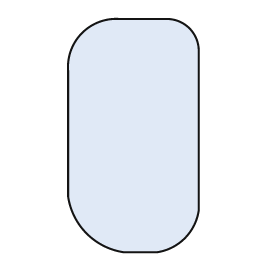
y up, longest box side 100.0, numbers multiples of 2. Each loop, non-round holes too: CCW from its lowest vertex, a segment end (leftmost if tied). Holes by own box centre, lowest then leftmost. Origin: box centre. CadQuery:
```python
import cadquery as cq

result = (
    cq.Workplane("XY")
    .moveTo(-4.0, -50.0)
    .lineTo(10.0, -50.0)
    .threePointArc((22.0, -44.0), (28.0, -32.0))
    .lineTo(28.0, 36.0)
    .threePointArc((24.0, 46.0), (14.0, 50.0))
    .lineTo(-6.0, 50.0)
    .threePointArc((-22.0, 44.0), (-28.0, 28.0))
    .lineTo(-28.0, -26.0)
    .threePointArc((-20.0, -42.0), (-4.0, -50.0))
    .close()
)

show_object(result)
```